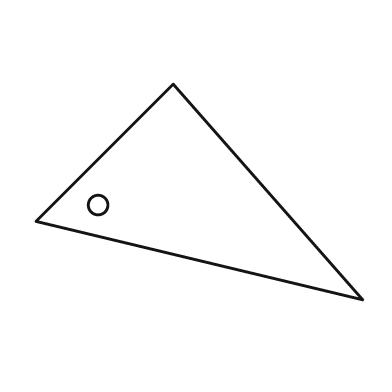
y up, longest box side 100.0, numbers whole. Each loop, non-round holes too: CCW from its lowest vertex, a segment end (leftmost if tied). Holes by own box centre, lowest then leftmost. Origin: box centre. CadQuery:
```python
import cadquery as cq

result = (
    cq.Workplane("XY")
    .moveTo(50.0, -33.0)
    .lineTo(-8.0, 33.0)
    .lineTo(-50.0, -9.0)
    .close()
    .moveTo(-31.0, -4.0)
    .circle(3.0)
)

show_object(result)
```